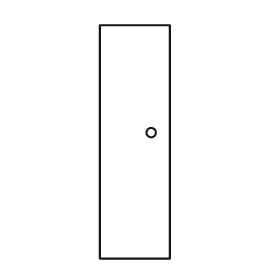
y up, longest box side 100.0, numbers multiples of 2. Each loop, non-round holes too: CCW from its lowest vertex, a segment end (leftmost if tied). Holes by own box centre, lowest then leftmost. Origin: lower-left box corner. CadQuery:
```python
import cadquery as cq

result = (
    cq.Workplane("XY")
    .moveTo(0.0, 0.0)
    .lineTo(30.0, 0.0)
    .lineTo(30.0, 100.0)
    .lineTo(0.0, 100.0)
    .close()
    .moveTo(22.0, 54.0)
    .circle(2.0)
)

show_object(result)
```